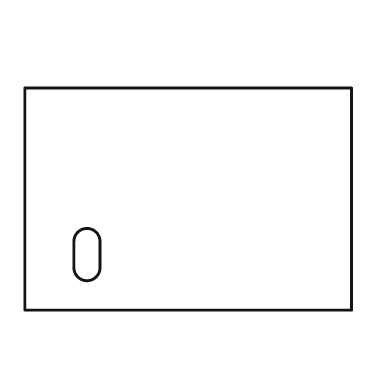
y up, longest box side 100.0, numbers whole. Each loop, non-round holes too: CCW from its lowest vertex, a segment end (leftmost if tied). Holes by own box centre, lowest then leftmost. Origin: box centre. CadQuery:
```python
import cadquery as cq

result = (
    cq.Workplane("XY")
    .moveTo(-50.0, -34.0)
    .lineTo(50.0, -34.0)
    .lineTo(50.0, 34.0)
    .lineTo(-50.0, 34.0)
    .close()
    .moveTo(-35.0, -21.0)
    .threePointArc((-31.0, -25.0), (-27.0, -21.0))
    .lineTo(-27.0, -13.0)
    .threePointArc((-31.0, -9.0), (-35.0, -13.0))
    .close()
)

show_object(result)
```